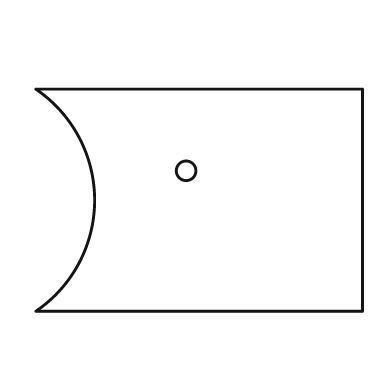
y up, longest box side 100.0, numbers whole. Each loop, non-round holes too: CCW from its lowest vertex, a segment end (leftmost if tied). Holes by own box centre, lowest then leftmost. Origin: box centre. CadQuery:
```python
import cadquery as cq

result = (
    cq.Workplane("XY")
    .moveTo(-50.0, -34.0)
    .lineTo(50.0, -34.0)
    .lineTo(50.0, 34.0)
    .lineTo(-50.0, 34.0)
    .threePointArc((-32.0, 0.0), (-50.0, -34.0))
    .close()
    .moveTo(-4.0, 9.0)
    .circle(3.0)
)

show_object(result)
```